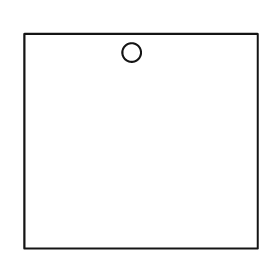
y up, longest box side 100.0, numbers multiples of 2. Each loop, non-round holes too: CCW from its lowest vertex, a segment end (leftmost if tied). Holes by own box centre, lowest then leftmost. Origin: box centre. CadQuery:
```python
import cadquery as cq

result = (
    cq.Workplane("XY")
    .moveTo(-50.0, -46.0)
    .lineTo(50.0, -46.0)
    .lineTo(50.0, 46.0)
    .lineTo(-50.0, 46.0)
    .close()
    .moveTo(-4.0, 38.0)
    .circle(4.0)
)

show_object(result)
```